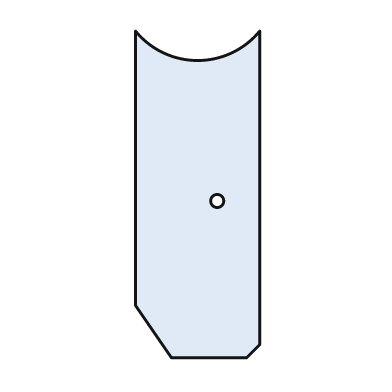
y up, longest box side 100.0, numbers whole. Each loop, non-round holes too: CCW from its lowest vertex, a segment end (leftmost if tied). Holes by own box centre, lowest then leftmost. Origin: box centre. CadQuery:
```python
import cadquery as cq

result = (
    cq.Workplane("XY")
    .moveTo(-8.0, -50.0)
    .lineTo(15.0, -50.0)
    .lineTo(19.0, -46.0)
    .lineTo(19.0, 50.0)
    .threePointArc((0.0, 41.0), (-19.0, 50.0))
    .lineTo(-19.0, -34.0)
    .close()
    .moveTo(6.0, -2.0)
    .circle(2.0)
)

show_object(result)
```